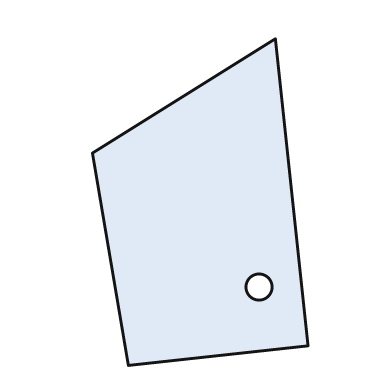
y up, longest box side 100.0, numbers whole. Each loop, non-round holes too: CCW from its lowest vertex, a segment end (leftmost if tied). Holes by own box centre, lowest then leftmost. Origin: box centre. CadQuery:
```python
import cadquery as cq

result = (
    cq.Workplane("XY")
    .moveTo(-22.0, -50.0)
    .lineTo(33.0, -44.0)
    .lineTo(23.0, 50.0)
    .lineTo(-33.0, 15.0)
    .close()
    .moveTo(18.0, -26.0)
    .circle(4.0)
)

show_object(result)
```